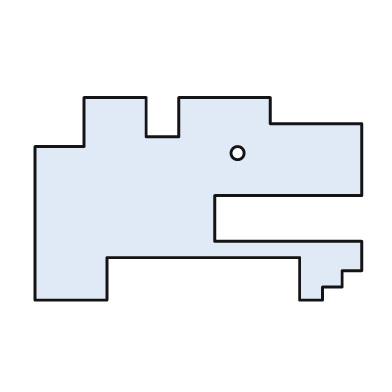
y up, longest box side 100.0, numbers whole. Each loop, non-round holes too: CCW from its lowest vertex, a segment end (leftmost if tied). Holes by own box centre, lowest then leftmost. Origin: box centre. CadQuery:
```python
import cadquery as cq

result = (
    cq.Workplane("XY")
    .moveTo(-50.0, -31.0)
    .lineTo(-28.0, -31.0)
    .lineTo(-28.0, -18.0)
    .lineTo(31.0, -18.0)
    .lineTo(31.0, -31.0)
    .lineTo(38.0, -31.0)
    .lineTo(38.0, -27.0)
    .lineTo(44.0, -27.0)
    .lineTo(44.0, -22.0)
    .lineTo(50.0, -22.0)
    .lineTo(50.0, -13.0)
    .lineTo(5.0, -13.0)
    .lineTo(5.0, 1.0)
    .lineTo(50.0, 1.0)
    .lineTo(50.0, 23.0)
    .lineTo(22.0, 23.0)
    .lineTo(22.0, 31.0)
    .lineTo(-6.0, 31.0)
    .lineTo(-6.0, 19.0)
    .lineTo(-16.0, 19.0)
    .lineTo(-16.0, 31.0)
    .lineTo(-35.0, 31.0)
    .lineTo(-35.0, 16.0)
    .lineTo(-50.0, 16.0)
    .close()
    .moveTo(12.0, 14.0)
    .circle(2.0)
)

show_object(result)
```